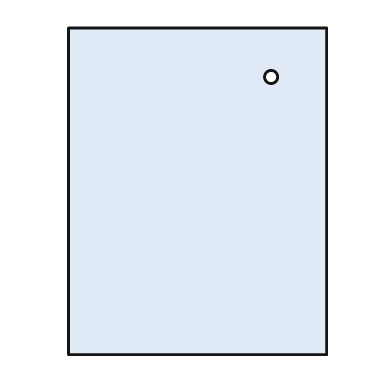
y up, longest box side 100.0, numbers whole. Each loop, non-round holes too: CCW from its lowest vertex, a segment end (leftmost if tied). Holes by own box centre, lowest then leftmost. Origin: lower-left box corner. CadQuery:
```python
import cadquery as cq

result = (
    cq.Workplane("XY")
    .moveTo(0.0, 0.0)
    .lineTo(79.0, 0.0)
    .lineTo(79.0, 100.0)
    .lineTo(0.0, 100.0)
    .close()
    .moveTo(62.0, 85.0)
    .circle(2.0)
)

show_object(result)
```